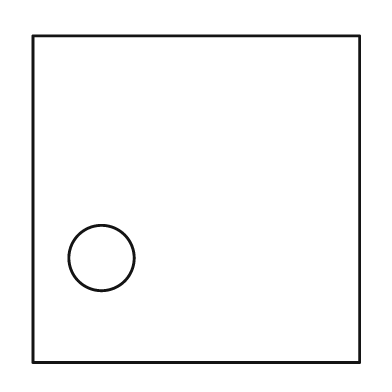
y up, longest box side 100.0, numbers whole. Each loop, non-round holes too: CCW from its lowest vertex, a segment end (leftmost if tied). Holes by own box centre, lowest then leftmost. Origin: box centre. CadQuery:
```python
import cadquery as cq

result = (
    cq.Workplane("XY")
    .moveTo(-50.0, -50.0)
    .lineTo(50.0, -50.0)
    .lineTo(50.0, 50.0)
    .lineTo(-50.0, 50.0)
    .close()
    .moveTo(-29.0, -18.0)
    .circle(10.0)
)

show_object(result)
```